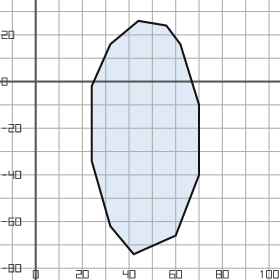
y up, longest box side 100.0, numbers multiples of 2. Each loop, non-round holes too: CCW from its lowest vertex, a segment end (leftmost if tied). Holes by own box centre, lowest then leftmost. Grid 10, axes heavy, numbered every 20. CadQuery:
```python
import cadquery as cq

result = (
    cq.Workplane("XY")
    .moveTo(42.0, -74.0)
    .lineTo(60.0, -66.0)
    .lineTo(70.0, -40.0)
    .lineTo(70.0, -10.0)
    .lineTo(62.0, 16.0)
    .lineTo(56.0, 24.0)
    .lineTo(44.0, 26.0)
    .lineTo(32.0, 16.0)
    .lineTo(24.0, -2.0)
    .lineTo(24.0, -34.0)
    .lineTo(32.0, -62.0)
    .close()
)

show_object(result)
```